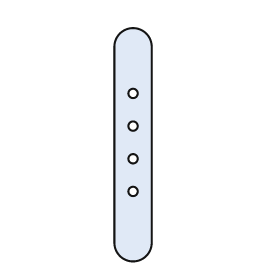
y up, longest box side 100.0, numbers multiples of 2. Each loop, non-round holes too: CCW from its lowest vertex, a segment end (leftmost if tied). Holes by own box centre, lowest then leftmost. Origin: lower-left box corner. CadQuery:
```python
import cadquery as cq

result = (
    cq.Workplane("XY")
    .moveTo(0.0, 8.0)
    .threePointArc((8.0, 0.0), (16.0, 8.0))
    .lineTo(16.0, 92.0)
    .threePointArc((8.0, 100.0), (0.0, 92.0))
    .close()
    .moveTo(8.0, 30.0)
    .circle(2.0)
    .moveTo(8.0, 44.0)
    .circle(2.0)
    .moveTo(8.0, 58.0)
    .circle(2.0)
    .moveTo(8.0, 72.0)
    .circle(2.0)
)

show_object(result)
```